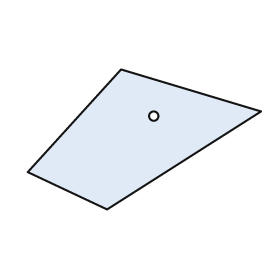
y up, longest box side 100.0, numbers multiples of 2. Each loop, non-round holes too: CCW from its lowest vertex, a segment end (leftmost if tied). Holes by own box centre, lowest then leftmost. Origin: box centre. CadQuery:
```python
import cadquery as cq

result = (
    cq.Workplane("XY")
    .moveTo(-16.0, -30.0)
    .lineTo(50.0, 12.0)
    .lineTo(-10.0, 30.0)
    .lineTo(-50.0, -14.0)
    .close()
    .moveTo(4.0, 10.0)
    .circle(2.0)
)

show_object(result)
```